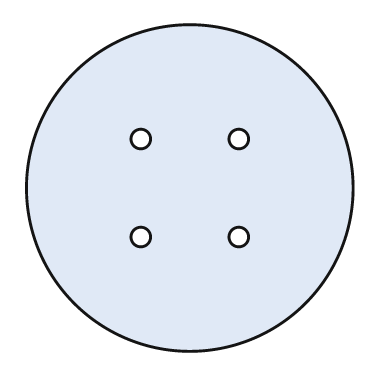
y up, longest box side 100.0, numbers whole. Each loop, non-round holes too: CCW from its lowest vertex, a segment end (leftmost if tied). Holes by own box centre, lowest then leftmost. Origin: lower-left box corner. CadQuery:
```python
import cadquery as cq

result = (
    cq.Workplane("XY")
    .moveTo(50.0, 50.0)
    .circle(50.0)
    .moveTo(35.0, 35.0)
    .circle(3.0)
    .moveTo(65.0, 35.0)
    .circle(3.0)
    .moveTo(35.0, 65.0)
    .circle(3.0)
    .moveTo(65.0, 65.0)
    .circle(3.0)
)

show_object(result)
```